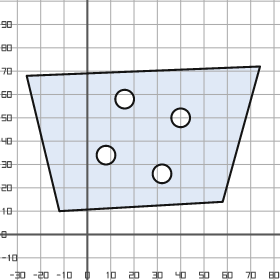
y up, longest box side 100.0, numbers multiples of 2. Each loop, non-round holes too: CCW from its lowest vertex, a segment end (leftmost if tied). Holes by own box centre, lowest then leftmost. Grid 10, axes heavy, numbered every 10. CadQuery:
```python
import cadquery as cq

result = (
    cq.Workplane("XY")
    .moveTo(-12.0, 10.0)
    .lineTo(58.0, 14.0)
    .lineTo(74.0, 72.0)
    .lineTo(-26.0, 68.0)
    .close()
    .moveTo(32.0, 26.0)
    .circle(4.0)
    .moveTo(8.0, 34.0)
    .circle(4.0)
    .moveTo(40.0, 50.0)
    .circle(4.0)
    .moveTo(16.0, 58.0)
    .circle(4.0)
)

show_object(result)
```